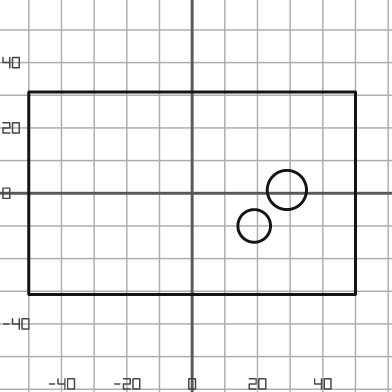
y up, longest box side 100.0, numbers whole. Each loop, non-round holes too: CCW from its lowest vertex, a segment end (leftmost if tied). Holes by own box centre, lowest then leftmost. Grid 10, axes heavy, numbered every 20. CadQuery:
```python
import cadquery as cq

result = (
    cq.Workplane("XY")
    .moveTo(-50.0, -31.0)
    .lineTo(50.0, -31.0)
    .lineTo(50.0, 31.0)
    .lineTo(-50.0, 31.0)
    .close()
    .moveTo(19.0, -10.0)
    .circle(5.0)
    .moveTo(29.0, 1.0)
    .circle(6.0)
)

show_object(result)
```